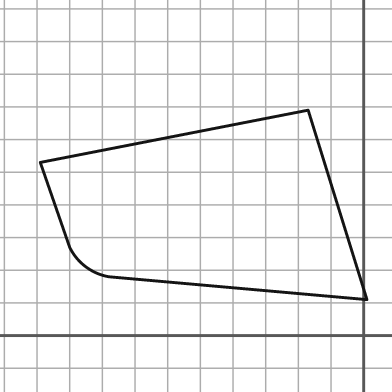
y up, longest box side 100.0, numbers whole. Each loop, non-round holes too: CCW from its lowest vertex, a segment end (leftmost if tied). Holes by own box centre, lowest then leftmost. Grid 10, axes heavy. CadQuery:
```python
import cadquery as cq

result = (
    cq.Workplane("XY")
    .moveTo(1.0, 11.0)
    .lineTo(-17.0, 69.0)
    .lineTo(-99.0, 53.0)
    .lineTo(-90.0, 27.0)
    .threePointArc((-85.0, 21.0), (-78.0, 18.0))
    .close()
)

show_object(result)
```